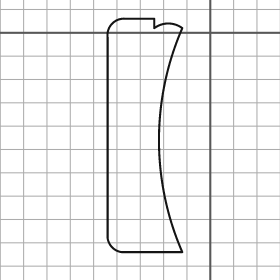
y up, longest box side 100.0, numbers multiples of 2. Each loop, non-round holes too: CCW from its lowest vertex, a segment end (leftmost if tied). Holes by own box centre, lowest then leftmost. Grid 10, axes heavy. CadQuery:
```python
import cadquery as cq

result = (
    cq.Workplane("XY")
    .moveTo(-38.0, -94.0)
    .lineTo(-12.0, -94.0)
    .threePointArc((-22.0, -46.0), (-12.0, 2.0))
    .threePointArc((-18.0, 4.0), (-24.0, 2.0))
    .lineTo(-24.0, 6.0)
    .lineTo(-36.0, 6.0)
    .threePointArc((-42.0, 4.0), (-44.0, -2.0))
    .lineTo(-44.0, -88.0)
    .threePointArc((-42.0, -92.0), (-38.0, -94.0))
    .close()
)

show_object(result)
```